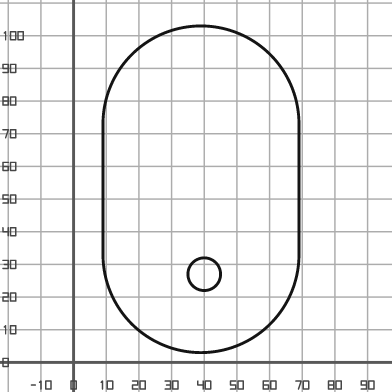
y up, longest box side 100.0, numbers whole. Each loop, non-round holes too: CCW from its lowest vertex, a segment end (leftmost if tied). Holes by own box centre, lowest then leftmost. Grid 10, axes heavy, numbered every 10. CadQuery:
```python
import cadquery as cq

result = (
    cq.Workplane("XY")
    .moveTo(9.0, 33.0)
    .threePointArc((39.0, 3.0), (69.0, 33.0))
    .lineTo(69.0, 73.0)
    .threePointArc((39.0, 103.0), (9.0, 73.0))
    .close()
    .moveTo(40.0, 27.0)
    .circle(5.0)
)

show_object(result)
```